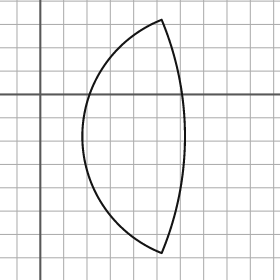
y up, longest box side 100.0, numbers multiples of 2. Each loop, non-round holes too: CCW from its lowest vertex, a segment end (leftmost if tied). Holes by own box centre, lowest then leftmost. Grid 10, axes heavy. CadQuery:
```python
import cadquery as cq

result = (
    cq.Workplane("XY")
    .moveTo(52.0, -68.0)
    .threePointArc((62.0, -18.0), (52.0, 32.0))
    .threePointArc((18.0, -18.0), (52.0, -68.0))
    .close()
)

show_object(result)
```